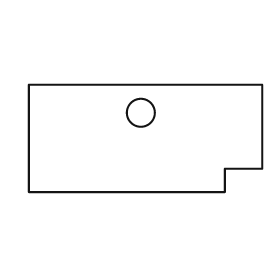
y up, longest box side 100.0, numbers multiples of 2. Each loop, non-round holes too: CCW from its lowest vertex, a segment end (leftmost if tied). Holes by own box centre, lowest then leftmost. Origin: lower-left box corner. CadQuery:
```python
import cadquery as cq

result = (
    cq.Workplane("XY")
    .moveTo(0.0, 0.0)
    .lineTo(84.0, 0.0)
    .lineTo(84.0, 10.0)
    .lineTo(100.0, 10.0)
    .lineTo(100.0, 46.0)
    .lineTo(0.0, 46.0)
    .close()
    .moveTo(48.0, 34.0)
    .circle(6.0)
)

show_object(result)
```